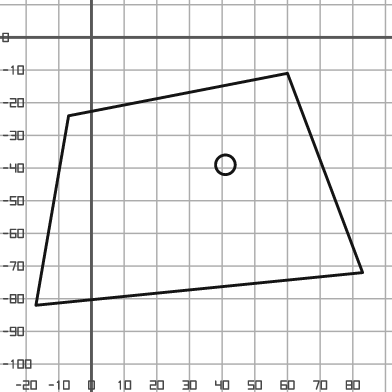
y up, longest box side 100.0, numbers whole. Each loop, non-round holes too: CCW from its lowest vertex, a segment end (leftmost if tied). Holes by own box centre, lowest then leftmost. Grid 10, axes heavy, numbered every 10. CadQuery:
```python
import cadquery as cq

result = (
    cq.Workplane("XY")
    .moveTo(-17.0, -82.0)
    .lineTo(83.0, -72.0)
    .lineTo(60.0, -11.0)
    .lineTo(-7.0, -24.0)
    .close()
    .moveTo(41.0, -39.0)
    .circle(3.0)
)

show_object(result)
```